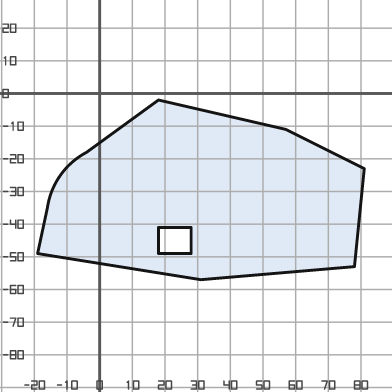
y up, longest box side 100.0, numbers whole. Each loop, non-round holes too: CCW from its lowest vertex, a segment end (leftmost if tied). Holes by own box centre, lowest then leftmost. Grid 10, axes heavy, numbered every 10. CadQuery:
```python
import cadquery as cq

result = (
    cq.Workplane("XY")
    .moveTo(31.0, -57.0)
    .lineTo(78.0, -53.0)
    .lineTo(81.0, -23.0)
    .lineTo(57.0, -11.0)
    .lineTo(18.0, -2.0)
    .lineTo(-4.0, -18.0)
    .threePointArc((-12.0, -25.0), (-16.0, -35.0))
    .lineTo(-19.0, -49.0)
    .close()
    .moveTo(18.0, -49.0)
    .lineTo(28.0, -49.0)
    .lineTo(28.0, -41.0)
    .lineTo(18.0, -41.0)
    .close()
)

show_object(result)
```